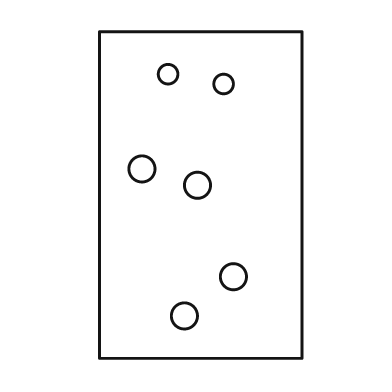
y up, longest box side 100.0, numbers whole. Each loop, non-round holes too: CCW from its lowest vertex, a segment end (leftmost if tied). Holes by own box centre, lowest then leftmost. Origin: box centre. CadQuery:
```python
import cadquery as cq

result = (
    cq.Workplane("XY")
    .moveTo(-31.0, -50.0)
    .lineTo(31.0, -50.0)
    .lineTo(31.0, 50.0)
    .lineTo(-31.0, 50.0)
    .close()
    .moveTo(-5.0, -37.0)
    .circle(4.0)
    .moveTo(10.0, -25.0)
    .circle(4.0)
    .moveTo(-1.0, 3.0)
    .circle(4.0)
    .moveTo(-18.0, 8.0)
    .circle(4.0)
    .moveTo(7.0, 34.0)
    .circle(3.0)
    .moveTo(-10.0, 37.0)
    .circle(3.0)
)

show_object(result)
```